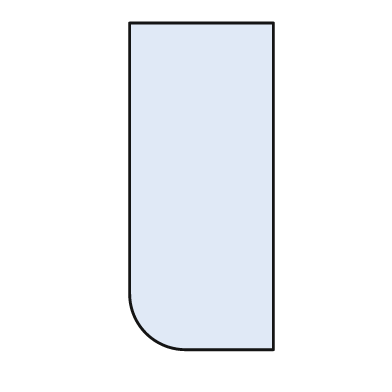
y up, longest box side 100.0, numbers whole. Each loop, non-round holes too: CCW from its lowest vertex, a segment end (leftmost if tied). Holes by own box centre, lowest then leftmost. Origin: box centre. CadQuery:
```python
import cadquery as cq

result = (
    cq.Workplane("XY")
    .moveTo(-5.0, -50.0)
    .lineTo(22.0, -50.0)
    .lineTo(22.0, 50.0)
    .lineTo(-22.0, 50.0)
    .lineTo(-22.0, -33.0)
    .threePointArc((-17.0, -45.0), (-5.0, -50.0))
    .close()
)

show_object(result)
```